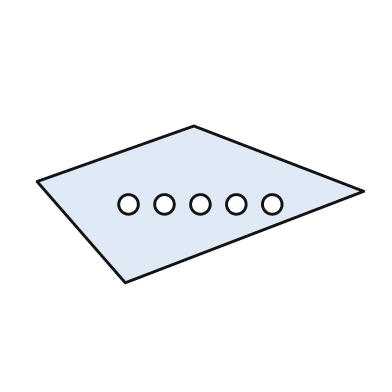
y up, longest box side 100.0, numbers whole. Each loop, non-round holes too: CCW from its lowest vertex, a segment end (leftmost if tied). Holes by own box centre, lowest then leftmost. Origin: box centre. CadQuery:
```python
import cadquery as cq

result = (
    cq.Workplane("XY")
    .moveTo(-23.0, -24.0)
    .lineTo(50.0, 4.0)
    .lineTo(-2.0, 24.0)
    .lineTo(-50.0, 7.0)
    .close()
    .moveTo(-22.0, 0.0)
    .circle(3.0)
    .moveTo(-11.0, 0.0)
    .circle(3.0)
    .moveTo(0.0, 0.0)
    .circle(3.0)
    .moveTo(11.0, 0.0)
    .circle(3.0)
    .moveTo(22.0, 0.0)
    .circle(3.0)
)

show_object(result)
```